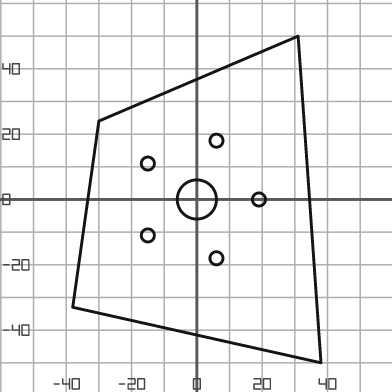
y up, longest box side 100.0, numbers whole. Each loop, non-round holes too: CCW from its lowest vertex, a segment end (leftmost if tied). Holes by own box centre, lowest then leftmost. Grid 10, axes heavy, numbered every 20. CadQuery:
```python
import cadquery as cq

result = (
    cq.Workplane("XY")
    .moveTo(38.0, -50.0)
    .lineTo(31.0, 50.0)
    .lineTo(-30.0, 24.0)
    .lineTo(-38.0, -33.0)
    .close()
    .moveTo(6.0, -18.0)
    .circle(2.0)
    .moveTo(-15.0, -11.0)
    .circle(2.0)
    .moveTo(0.0, 0.0)
    .circle(6.0)
    .moveTo(19.0, 0.0)
    .circle(2.0)
    .moveTo(-15.0, 11.0)
    .circle(2.0)
    .moveTo(6.0, 18.0)
    .circle(2.0)
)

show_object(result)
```